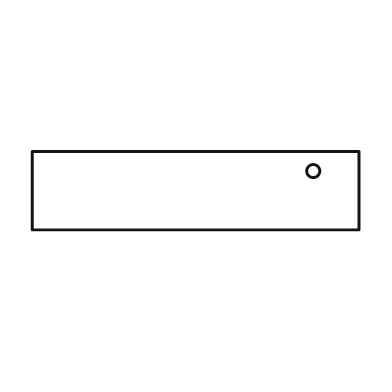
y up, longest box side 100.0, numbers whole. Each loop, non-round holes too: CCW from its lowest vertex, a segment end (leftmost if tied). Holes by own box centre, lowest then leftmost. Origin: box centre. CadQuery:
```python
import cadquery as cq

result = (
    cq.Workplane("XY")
    .moveTo(-50.0, -12.0)
    .lineTo(50.0, -12.0)
    .lineTo(50.0, 12.0)
    .lineTo(-50.0, 12.0)
    .close()
    .moveTo(36.0, 6.0)
    .circle(2.0)
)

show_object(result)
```